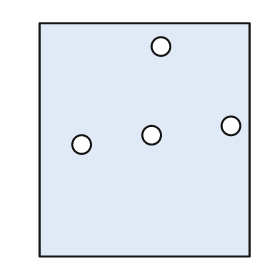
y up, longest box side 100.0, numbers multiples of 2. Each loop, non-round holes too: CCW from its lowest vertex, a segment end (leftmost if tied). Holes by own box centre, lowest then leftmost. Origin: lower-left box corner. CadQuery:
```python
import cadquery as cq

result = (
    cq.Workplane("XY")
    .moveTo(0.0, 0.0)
    .lineTo(90.0, 0.0)
    .lineTo(90.0, 100.0)
    .lineTo(0.0, 100.0)
    .close()
    .moveTo(18.0, 48.0)
    .circle(4.0)
    .moveTo(48.0, 52.0)
    .circle(4.0)
    .moveTo(82.0, 56.0)
    .circle(4.0)
    .moveTo(52.0, 90.0)
    .circle(4.0)
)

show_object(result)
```